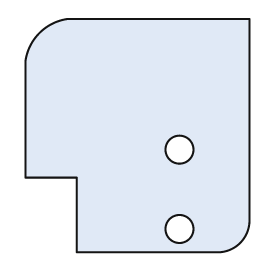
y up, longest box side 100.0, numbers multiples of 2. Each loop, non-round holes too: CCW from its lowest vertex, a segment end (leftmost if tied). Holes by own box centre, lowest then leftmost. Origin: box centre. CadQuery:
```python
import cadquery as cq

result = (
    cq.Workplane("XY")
    .moveTo(-26.0, -50.0)
    .lineTo(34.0, -50.0)
    .threePointArc((44.0, -46.0), (48.0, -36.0))
    .lineTo(48.0, 50.0)
    .lineTo(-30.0, 50.0)
    .threePointArc((-42.0, 44.0), (-48.0, 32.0))
    .lineTo(-48.0, -18.0)
    .lineTo(-26.0, -18.0)
    .close()
    .moveTo(18.0, -40.0)
    .circle(6.0)
    .moveTo(18.0, -6.0)
    .circle(6.0)
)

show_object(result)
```